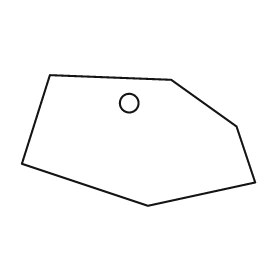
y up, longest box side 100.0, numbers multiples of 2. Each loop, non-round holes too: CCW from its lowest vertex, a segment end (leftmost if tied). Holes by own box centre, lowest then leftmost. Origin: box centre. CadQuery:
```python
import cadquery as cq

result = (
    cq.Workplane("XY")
    .moveTo(4.0, -28.0)
    .lineTo(50.0, -18.0)
    .lineTo(42.0, 6.0)
    .lineTo(14.0, 26.0)
    .lineTo(-38.0, 28.0)
    .lineTo(-50.0, -10.0)
    .close()
    .moveTo(-4.0, 16.0)
    .circle(4.0)
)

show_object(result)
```